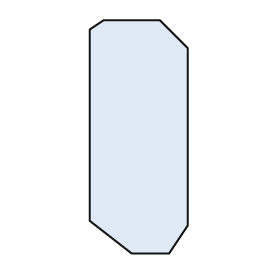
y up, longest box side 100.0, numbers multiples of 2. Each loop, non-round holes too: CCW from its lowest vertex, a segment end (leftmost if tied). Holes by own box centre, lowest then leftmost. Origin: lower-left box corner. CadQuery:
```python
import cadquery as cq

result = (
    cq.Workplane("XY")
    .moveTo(18.0, 0.0)
    .lineTo(34.0, 0.0)
    .lineTo(42.0, 12.0)
    .lineTo(42.0, 88.0)
    .lineTo(30.0, 100.0)
    .lineTo(6.0, 100.0)
    .lineTo(0.0, 96.0)
    .lineTo(0.0, 14.0)
    .close()
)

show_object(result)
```